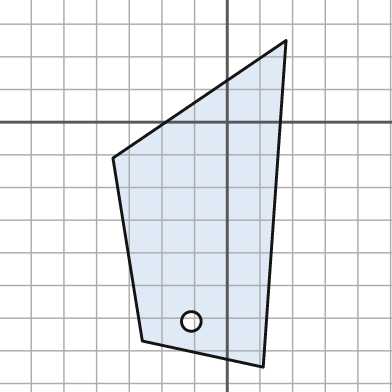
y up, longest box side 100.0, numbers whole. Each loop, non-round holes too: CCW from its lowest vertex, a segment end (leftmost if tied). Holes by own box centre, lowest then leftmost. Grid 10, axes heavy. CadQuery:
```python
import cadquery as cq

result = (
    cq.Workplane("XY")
    .moveTo(11.0, -75.0)
    .lineTo(18.0, 25.0)
    .lineTo(-35.0, -11.0)
    .lineTo(-26.0, -67.0)
    .close()
    .moveTo(-11.0, -61.0)
    .circle(3.0)
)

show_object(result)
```